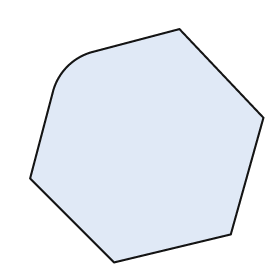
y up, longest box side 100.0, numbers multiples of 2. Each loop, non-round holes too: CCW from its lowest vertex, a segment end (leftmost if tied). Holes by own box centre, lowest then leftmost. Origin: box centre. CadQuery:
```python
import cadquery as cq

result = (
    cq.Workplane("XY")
    .moveTo(-14.0, -50.0)
    .lineTo(36.0, -38.0)
    .lineTo(50.0, 12.0)
    .lineTo(14.0, 50.0)
    .lineTo(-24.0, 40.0)
    .threePointArc((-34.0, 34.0), (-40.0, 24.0))
    .lineTo(-50.0, -14.0)
    .close()
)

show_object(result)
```